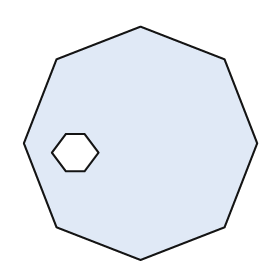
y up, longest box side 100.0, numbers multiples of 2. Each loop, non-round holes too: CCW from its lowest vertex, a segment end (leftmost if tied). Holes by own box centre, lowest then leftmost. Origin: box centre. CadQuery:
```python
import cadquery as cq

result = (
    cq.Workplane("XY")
    .moveTo(0.0, -50.0)
    .lineTo(36.0, -36.0)
    .lineTo(50.0, 0.0)
    .lineTo(36.0, 36.0)
    .lineTo(0.0, 50.0)
    .lineTo(-36.0, 36.0)
    .lineTo(-50.0, 0.0)
    .lineTo(-36.0, -36.0)
    .close()
    .moveTo(-32.0, -12.0)
    .lineTo(-24.0, -12.0)
    .lineTo(-18.0, -4.0)
    .lineTo(-24.0, 4.0)
    .lineTo(-32.0, 4.0)
    .lineTo(-38.0, -4.0)
    .close()
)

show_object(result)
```